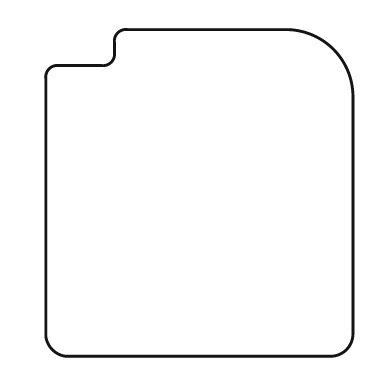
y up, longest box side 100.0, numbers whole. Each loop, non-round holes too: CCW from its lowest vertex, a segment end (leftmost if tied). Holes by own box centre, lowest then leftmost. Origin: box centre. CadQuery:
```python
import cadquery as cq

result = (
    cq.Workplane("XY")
    .moveTo(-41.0, -50.0)
    .lineTo(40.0, -50.0)
    .threePointArc((45.0, -48.0), (47.0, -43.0))
    .lineTo(47.0, 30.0)
    .threePointArc((41.0, 44.0), (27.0, 50.0))
    .lineTo(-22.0, 50.0)
    .threePointArc((-25.0, 49.0), (-26.0, 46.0))
    .lineTo(-26.0, 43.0)
    .threePointArc((-27.0, 40.0), (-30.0, 39.0))
    .lineTo(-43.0, 39.0)
    .threePointArc((-46.0, 38.0), (-47.0, 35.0))
    .lineTo(-47.0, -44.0)
    .threePointArc((-45.0, -48.0), (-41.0, -50.0))
    .close()
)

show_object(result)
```